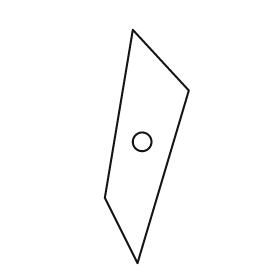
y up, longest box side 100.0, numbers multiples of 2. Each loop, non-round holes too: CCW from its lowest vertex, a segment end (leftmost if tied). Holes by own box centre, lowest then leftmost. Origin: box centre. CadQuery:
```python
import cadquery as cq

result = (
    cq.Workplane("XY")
    .moveTo(-4.0, -50.0)
    .lineTo(18.0, 24.0)
    .lineTo(-6.0, 50.0)
    .lineTo(-18.0, -22.0)
    .close()
    .moveTo(-2.0, 2.0)
    .circle(4.0)
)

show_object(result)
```